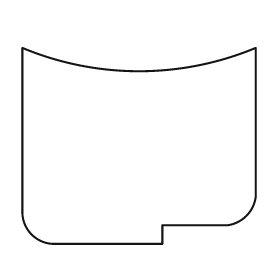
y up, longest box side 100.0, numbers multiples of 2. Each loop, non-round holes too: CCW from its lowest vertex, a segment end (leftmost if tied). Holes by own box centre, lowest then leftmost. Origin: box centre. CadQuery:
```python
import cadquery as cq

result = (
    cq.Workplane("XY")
    .moveTo(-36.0, -42.0)
    .lineTo(10.0, -42.0)
    .lineTo(10.0, -34.0)
    .lineTo(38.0, -34.0)
    .threePointArc((46.0, -30.0), (50.0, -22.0))
    .lineTo(50.0, 42.0)
    .threePointArc((0.0, 32.0), (-50.0, 42.0))
    .lineTo(-50.0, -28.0)
    .threePointArc((-46.0, -38.0), (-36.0, -42.0))
    .close()
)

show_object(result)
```